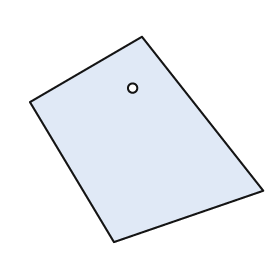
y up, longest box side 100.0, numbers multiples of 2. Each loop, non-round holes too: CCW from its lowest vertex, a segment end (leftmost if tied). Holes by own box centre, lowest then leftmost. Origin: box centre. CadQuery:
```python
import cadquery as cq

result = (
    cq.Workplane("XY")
    .moveTo(-14.0, -44.0)
    .lineTo(50.0, -22.0)
    .lineTo(-2.0, 44.0)
    .lineTo(-50.0, 16.0)
    .close()
    .moveTo(-6.0, 22.0)
    .circle(2.0)
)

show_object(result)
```